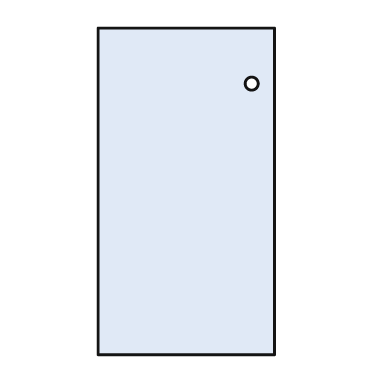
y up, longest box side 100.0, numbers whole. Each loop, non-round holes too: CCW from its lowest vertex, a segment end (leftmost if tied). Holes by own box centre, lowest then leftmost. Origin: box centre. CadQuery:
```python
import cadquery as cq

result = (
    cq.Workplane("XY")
    .moveTo(-27.0, -50.0)
    .lineTo(27.0, -50.0)
    .lineTo(27.0, 50.0)
    .lineTo(-27.0, 50.0)
    .close()
    .moveTo(20.0, 33.0)
    .circle(2.0)
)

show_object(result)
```